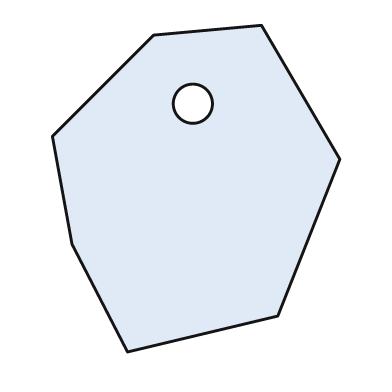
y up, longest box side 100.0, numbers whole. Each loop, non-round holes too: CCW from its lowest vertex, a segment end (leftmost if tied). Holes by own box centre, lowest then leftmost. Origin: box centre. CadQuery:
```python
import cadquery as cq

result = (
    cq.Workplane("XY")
    .moveTo(-21.0, -50.0)
    .lineTo(25.0, -39.0)
    .lineTo(44.0, 9.0)
    .lineTo(20.0, 50.0)
    .lineTo(-13.0, 47.0)
    .lineTo(-44.0, 16.0)
    .lineTo(-38.0, -17.0)
    .close()
    .moveTo(-1.0, 26.0)
    .circle(6.0)
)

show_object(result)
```